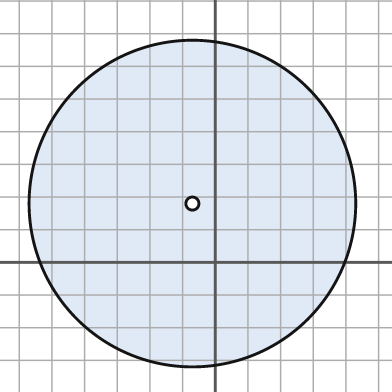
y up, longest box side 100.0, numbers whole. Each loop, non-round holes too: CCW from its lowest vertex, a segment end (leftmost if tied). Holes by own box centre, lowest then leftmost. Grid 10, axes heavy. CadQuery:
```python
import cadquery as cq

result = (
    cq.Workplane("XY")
    .moveTo(-7.0, 18.0)
    .circle(50.0)
    .moveTo(-7.0, 18.0)
    .circle(2.0)
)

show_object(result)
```